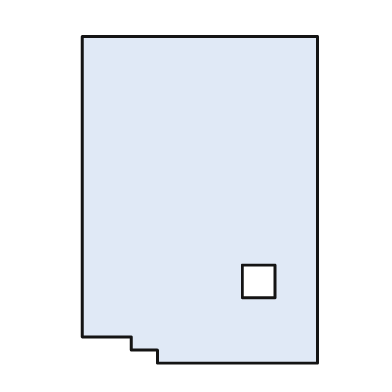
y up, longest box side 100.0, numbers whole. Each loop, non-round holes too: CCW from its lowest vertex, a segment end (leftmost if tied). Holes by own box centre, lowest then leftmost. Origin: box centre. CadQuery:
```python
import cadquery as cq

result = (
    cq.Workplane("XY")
    .moveTo(-13.0, -50.0)
    .lineTo(36.0, -50.0)
    .lineTo(36.0, 50.0)
    .lineTo(-36.0, 50.0)
    .lineTo(-36.0, -42.0)
    .lineTo(-21.0, -42.0)
    .lineTo(-21.0, -46.0)
    .lineTo(-13.0, -46.0)
    .close()
    .moveTo(13.0, -30.0)
    .lineTo(23.0, -30.0)
    .lineTo(23.0, -20.0)
    .lineTo(13.0, -20.0)
    .close()
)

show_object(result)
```